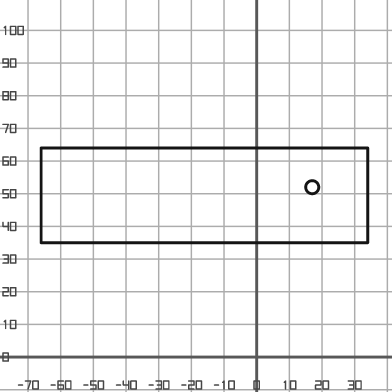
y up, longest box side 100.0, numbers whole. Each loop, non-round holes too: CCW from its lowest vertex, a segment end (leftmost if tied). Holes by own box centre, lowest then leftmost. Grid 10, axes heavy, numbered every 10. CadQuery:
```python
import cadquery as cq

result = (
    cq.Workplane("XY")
    .moveTo(-66.0, 35.0)
    .lineTo(34.0, 35.0)
    .lineTo(34.0, 64.0)
    .lineTo(-66.0, 64.0)
    .close()
    .moveTo(17.0, 52.0)
    .circle(2.0)
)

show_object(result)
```